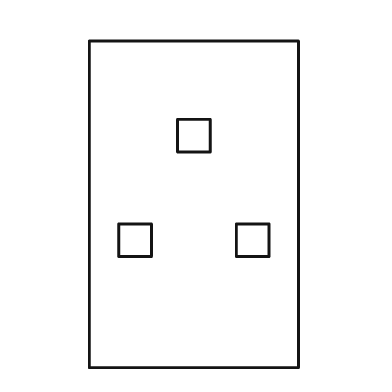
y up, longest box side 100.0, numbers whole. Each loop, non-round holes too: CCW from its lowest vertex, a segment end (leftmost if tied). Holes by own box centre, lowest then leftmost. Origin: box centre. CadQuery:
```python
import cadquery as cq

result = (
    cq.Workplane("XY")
    .moveTo(-32.0, -50.0)
    .lineTo(32.0, -50.0)
    .lineTo(32.0, 50.0)
    .lineTo(-32.0, 50.0)
    .close()
    .moveTo(-23.0, -16.0)
    .lineTo(-13.0, -16.0)
    .lineTo(-13.0, -6.0)
    .lineTo(-23.0, -6.0)
    .close()
    .moveTo(13.0, -16.0)
    .lineTo(23.0, -16.0)
    .lineTo(23.0, -6.0)
    .lineTo(13.0, -6.0)
    .close()
    .moveTo(-5.0, 16.0)
    .lineTo(5.0, 16.0)
    .lineTo(5.0, 26.0)
    .lineTo(-5.0, 26.0)
    .close()
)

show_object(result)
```